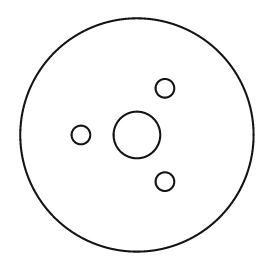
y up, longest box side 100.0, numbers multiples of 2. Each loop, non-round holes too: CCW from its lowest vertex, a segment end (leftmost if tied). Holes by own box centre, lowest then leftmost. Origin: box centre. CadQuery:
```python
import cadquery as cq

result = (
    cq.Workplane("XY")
    .moveTo(0.0, 0.0)
    .circle(50.0)
    .moveTo(12.0, -20.0)
    .circle(4.0)
    .moveTo(-24.0, 0.0)
    .circle(4.0)
    .moveTo(0.0, 0.0)
    .circle(10.0)
    .moveTo(12.0, 20.0)
    .circle(4.0)
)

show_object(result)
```